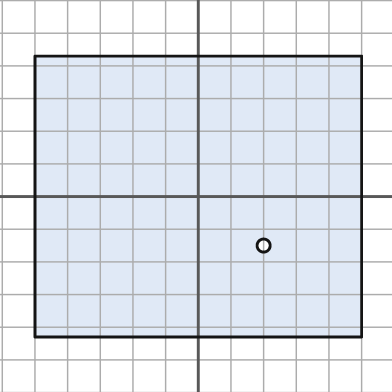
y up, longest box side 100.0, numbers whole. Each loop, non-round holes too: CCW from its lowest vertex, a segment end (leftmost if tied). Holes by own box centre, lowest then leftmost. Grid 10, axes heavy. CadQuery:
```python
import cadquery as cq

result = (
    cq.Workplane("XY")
    .moveTo(-50.0, -43.0)
    .lineTo(50.0, -43.0)
    .lineTo(50.0, 43.0)
    .lineTo(-50.0, 43.0)
    .close()
    .moveTo(20.0, -15.0)
    .circle(2.0)
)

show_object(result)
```